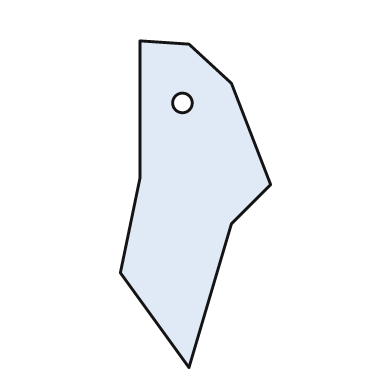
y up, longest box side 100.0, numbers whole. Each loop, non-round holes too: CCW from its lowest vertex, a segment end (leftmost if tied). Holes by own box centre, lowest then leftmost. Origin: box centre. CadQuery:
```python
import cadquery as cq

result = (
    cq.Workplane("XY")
    .moveTo(-2.0, -50.0)
    .lineTo(11.0, -6.0)
    .lineTo(23.0, 6.0)
    .lineTo(11.0, 37.0)
    .lineTo(-2.0, 49.0)
    .lineTo(-17.0, 50.0)
    .lineTo(-17.0, 8.0)
    .lineTo(-23.0, -21.0)
    .close()
    .moveTo(-4.0, 31.0)
    .circle(3.0)
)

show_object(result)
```